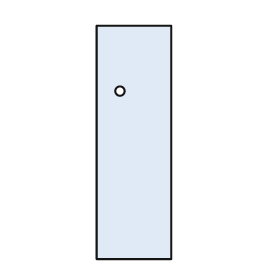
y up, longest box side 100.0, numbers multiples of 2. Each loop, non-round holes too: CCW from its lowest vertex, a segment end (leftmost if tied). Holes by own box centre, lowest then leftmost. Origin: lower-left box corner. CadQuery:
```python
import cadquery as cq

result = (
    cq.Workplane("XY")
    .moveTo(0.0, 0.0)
    .lineTo(32.0, 0.0)
    .lineTo(32.0, 100.0)
    .lineTo(0.0, 100.0)
    .close()
    .moveTo(10.0, 72.0)
    .circle(2.0)
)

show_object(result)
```